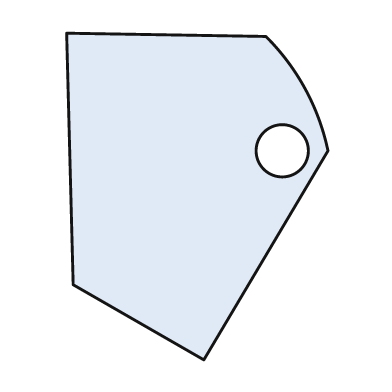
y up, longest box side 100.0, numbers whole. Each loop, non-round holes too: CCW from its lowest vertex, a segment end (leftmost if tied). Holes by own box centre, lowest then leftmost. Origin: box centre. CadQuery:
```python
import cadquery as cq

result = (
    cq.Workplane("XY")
    .moveTo(2.0, -50.0)
    .lineTo(40.0, 14.0)
    .threePointArc((33.0, 33.0), (21.0, 49.0))
    .lineTo(-40.0, 50.0)
    .lineTo(-38.0, -27.0)
    .close()
    .moveTo(26.0, 14.0)
    .circle(8.0)
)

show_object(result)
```